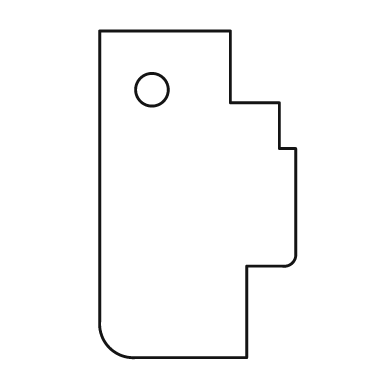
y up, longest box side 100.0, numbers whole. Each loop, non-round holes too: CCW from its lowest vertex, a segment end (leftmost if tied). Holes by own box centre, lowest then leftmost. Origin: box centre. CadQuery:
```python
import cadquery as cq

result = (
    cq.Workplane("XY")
    .moveTo(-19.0, -50.0)
    .lineTo(15.0, -50.0)
    .lineTo(15.0, -22.0)
    .lineTo(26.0, -22.0)
    .threePointArc((29.0, -21.0), (30.0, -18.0))
    .lineTo(30.0, 14.0)
    .lineTo(25.0, 14.0)
    .lineTo(25.0, 28.0)
    .lineTo(10.0, 28.0)
    .lineTo(10.0, 50.0)
    .lineTo(-30.0, 50.0)
    .lineTo(-30.0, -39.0)
    .threePointArc((-27.0, -47.0), (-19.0, -50.0))
    .close()
    .moveTo(-14.0, 32.0)
    .circle(5.0)
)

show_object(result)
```